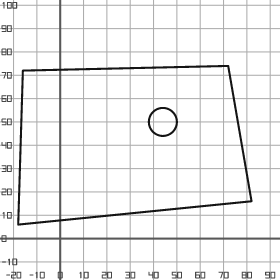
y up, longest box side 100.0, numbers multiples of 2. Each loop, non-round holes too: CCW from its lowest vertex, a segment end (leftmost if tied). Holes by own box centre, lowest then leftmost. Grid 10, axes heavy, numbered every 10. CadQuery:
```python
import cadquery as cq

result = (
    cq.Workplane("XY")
    .moveTo(-18.0, 6.0)
    .lineTo(82.0, 16.0)
    .lineTo(72.0, 74.0)
    .lineTo(-16.0, 72.0)
    .close()
    .moveTo(44.0, 50.0)
    .circle(6.0)
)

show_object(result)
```